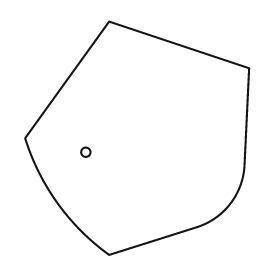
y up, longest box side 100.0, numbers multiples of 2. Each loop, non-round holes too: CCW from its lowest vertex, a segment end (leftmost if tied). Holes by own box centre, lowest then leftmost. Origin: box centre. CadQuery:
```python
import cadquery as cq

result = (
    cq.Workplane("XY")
    .moveTo(-12.0, -50.0)
    .lineTo(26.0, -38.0)
    .threePointArc((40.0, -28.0), (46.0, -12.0))
    .lineTo(48.0, 30.0)
    .lineTo(-12.0, 50.0)
    .lineTo(-48.0, 0.0)
    .threePointArc((-34.0, -28.0), (-12.0, -50.0))
    .close()
    .moveTo(-22.0, -6.0)
    .circle(2.0)
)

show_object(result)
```